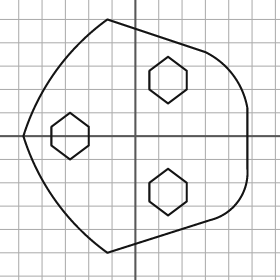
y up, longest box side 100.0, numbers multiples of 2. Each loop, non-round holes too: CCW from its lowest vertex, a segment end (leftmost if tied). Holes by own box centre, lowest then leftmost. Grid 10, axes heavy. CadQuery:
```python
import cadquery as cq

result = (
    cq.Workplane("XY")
    .moveTo(-12.0, -50.0)
    .lineTo(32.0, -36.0)
    .threePointArc((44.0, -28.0), (48.0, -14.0))
    .lineTo(48.0, 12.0)
    .threePointArc((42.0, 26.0), (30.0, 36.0))
    .lineTo(-12.0, 50.0)
    .threePointArc((-34.0, 28.0), (-48.0, 0.0))
    .threePointArc((-34.0, -28.0), (-12.0, -50.0))
    .close()
    .moveTo(14.0, -34.0)
    .lineTo(22.0, -28.0)
    .lineTo(22.0, -20.0)
    .lineTo(14.0, -14.0)
    .lineTo(6.0, -20.0)
    .lineTo(6.0, -28.0)
    .close()
    .moveTo(-28.0, -10.0)
    .lineTo(-20.0, -4.0)
    .lineTo(-20.0, 4.0)
    .lineTo(-28.0, 10.0)
    .lineTo(-36.0, 4.0)
    .lineTo(-36.0, -4.0)
    .close()
    .moveTo(14.0, 14.0)
    .lineTo(22.0, 20.0)
    .lineTo(22.0, 28.0)
    .lineTo(14.0, 34.0)
    .lineTo(6.0, 28.0)
    .lineTo(6.0, 20.0)
    .close()
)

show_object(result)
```